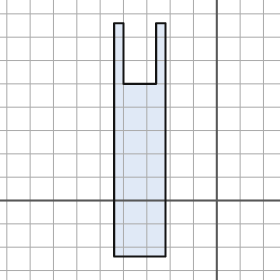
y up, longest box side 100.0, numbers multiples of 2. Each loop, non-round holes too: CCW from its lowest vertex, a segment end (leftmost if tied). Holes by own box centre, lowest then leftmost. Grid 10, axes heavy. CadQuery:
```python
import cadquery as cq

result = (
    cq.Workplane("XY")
    .moveTo(-44.0, -24.0)
    .lineTo(-22.0, -24.0)
    .lineTo(-22.0, 76.0)
    .lineTo(-26.0, 76.0)
    .lineTo(-26.0, 50.0)
    .lineTo(-40.0, 50.0)
    .lineTo(-40.0, 76.0)
    .lineTo(-44.0, 76.0)
    .close()
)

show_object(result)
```